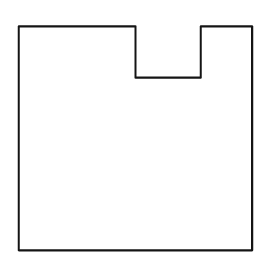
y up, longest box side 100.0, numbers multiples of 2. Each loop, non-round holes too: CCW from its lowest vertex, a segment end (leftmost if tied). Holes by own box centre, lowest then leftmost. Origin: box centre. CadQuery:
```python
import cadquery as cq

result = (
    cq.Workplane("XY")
    .moveTo(-50.0, -48.0)
    .lineTo(50.0, -48.0)
    .lineTo(50.0, 48.0)
    .lineTo(28.0, 48.0)
    .lineTo(28.0, 26.0)
    .lineTo(0.0, 26.0)
    .lineTo(0.0, 48.0)
    .lineTo(-50.0, 48.0)
    .close()
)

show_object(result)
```